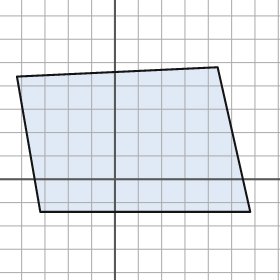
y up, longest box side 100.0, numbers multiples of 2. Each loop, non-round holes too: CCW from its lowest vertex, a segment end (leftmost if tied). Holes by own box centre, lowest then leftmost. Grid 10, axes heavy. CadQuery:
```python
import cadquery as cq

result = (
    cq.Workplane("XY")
    .moveTo(-32.0, -14.0)
    .lineTo(58.0, -14.0)
    .lineTo(44.0, 48.0)
    .lineTo(-42.0, 44.0)
    .close()
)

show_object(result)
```